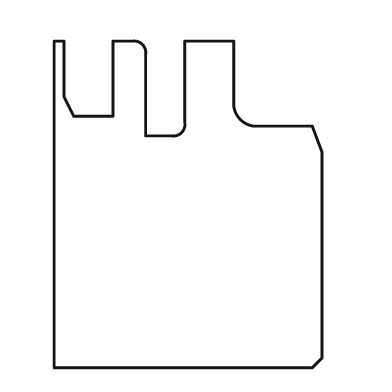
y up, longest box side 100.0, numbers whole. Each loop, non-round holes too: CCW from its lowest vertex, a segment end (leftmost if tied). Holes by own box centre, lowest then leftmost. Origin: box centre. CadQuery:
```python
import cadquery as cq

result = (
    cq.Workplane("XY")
    .moveTo(-41.0, -50.0)
    .lineTo(38.0, -50.0)
    .lineTo(41.0, -47.0)
    .lineTo(41.0, 16.0)
    .lineTo(38.0, 24.0)
    .lineTo(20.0, 24.0)
    .threePointArc((16.0, 26.0), (14.0, 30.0))
    .lineTo(14.0, 50.0)
    .lineTo(-1.0, 50.0)
    .lineTo(-1.0, 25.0)
    .threePointArc((-2.0, 22.0), (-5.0, 21.0))
    .lineTo(-13.0, 21.0)
    .lineTo(-13.0, 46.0)
    .threePointArc((-14.0, 49.0), (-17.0, 50.0))
    .lineTo(-23.0, 50.0)
    .lineTo(-23.0, 27.0)
    .lineTo(-35.0, 27.0)
    .lineTo(-38.0, 33.0)
    .lineTo(-38.0, 50.0)
    .lineTo(-41.0, 50.0)
    .close()
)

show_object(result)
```